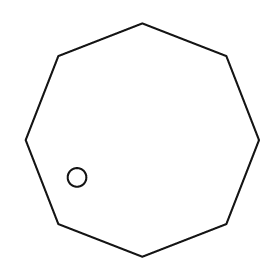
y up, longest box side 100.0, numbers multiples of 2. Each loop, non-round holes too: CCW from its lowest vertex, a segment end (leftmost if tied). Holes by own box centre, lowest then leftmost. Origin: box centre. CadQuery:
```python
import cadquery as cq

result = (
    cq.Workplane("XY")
    .moveTo(0.0, -50.0)
    .lineTo(36.0, -36.0)
    .lineTo(50.0, 0.0)
    .lineTo(36.0, 36.0)
    .lineTo(0.0, 50.0)
    .lineTo(-36.0, 36.0)
    .lineTo(-50.0, 0.0)
    .lineTo(-36.0, -36.0)
    .close()
    .moveTo(-28.0, -16.0)
    .circle(4.0)
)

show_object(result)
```